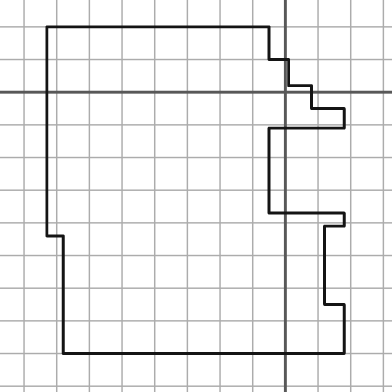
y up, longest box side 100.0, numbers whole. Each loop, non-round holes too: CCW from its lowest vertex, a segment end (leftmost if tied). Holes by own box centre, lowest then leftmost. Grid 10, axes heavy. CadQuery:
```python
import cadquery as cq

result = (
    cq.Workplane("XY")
    .moveTo(-68.0, -80.0)
    .lineTo(18.0, -80.0)
    .lineTo(18.0, -65.0)
    .lineTo(12.0, -65.0)
    .lineTo(12.0, -41.0)
    .lineTo(18.0, -41.0)
    .lineTo(18.0, -37.0)
    .lineTo(-5.0, -37.0)
    .lineTo(-5.0, -11.0)
    .lineTo(18.0, -11.0)
    .lineTo(18.0, -5.0)
    .lineTo(8.0, -5.0)
    .lineTo(8.0, 2.0)
    .lineTo(1.0, 2.0)
    .lineTo(1.0, 10.0)
    .lineTo(-5.0, 10.0)
    .lineTo(-5.0, 20.0)
    .lineTo(-73.0, 20.0)
    .lineTo(-73.0, -44.0)
    .lineTo(-68.0, -44.0)
    .close()
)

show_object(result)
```